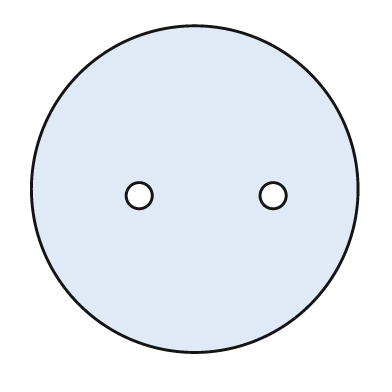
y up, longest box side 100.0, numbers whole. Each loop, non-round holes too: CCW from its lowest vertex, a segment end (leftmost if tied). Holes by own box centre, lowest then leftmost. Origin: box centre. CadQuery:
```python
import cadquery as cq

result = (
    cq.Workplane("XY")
    .moveTo(0.0, 0.0)
    .circle(50.0)
    .moveTo(-17.0, -2.0)
    .circle(4.0)
    .moveTo(24.0, -2.0)
    .circle(4.0)
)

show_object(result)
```